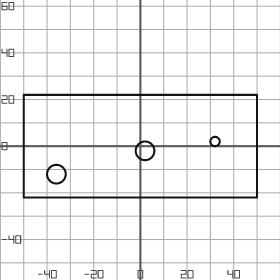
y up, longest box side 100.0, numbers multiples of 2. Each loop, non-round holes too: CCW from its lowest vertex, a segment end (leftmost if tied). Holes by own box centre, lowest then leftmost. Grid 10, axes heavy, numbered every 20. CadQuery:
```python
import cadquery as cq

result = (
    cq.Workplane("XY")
    .moveTo(-50.0, -22.0)
    .lineTo(50.0, -22.0)
    .lineTo(50.0, 22.0)
    .lineTo(-50.0, 22.0)
    .close()
    .moveTo(-36.0, -12.0)
    .circle(4.0)
    .moveTo(2.0, -2.0)
    .circle(4.0)
    .moveTo(32.0, 2.0)
    .circle(2.0)
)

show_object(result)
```